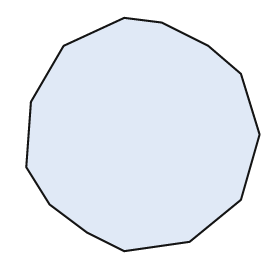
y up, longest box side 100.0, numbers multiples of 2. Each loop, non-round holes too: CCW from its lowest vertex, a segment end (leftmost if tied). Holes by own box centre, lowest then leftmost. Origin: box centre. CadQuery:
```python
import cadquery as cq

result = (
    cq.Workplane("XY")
    .moveTo(-8.0, -50.0)
    .lineTo(20.0, -46.0)
    .lineTo(42.0, -28.0)
    .lineTo(50.0, 0.0)
    .lineTo(42.0, 26.0)
    .lineTo(28.0, 38.0)
    .lineTo(8.0, 48.0)
    .lineTo(-8.0, 50.0)
    .lineTo(-34.0, 38.0)
    .lineTo(-48.0, 14.0)
    .lineTo(-50.0, -14.0)
    .lineTo(-40.0, -30.0)
    .lineTo(-24.0, -42.0)
    .close()
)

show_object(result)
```